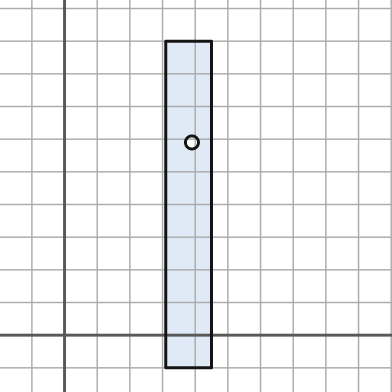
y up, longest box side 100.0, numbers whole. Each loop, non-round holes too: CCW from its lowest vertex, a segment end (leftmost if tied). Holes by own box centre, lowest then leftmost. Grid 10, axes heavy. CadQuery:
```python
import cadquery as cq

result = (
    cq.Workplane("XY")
    .moveTo(31.0, -10.0)
    .lineTo(45.0, -10.0)
    .lineTo(45.0, 90.0)
    .lineTo(31.0, 90.0)
    .close()
    .moveTo(39.0, 59.0)
    .circle(2.0)
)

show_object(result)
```